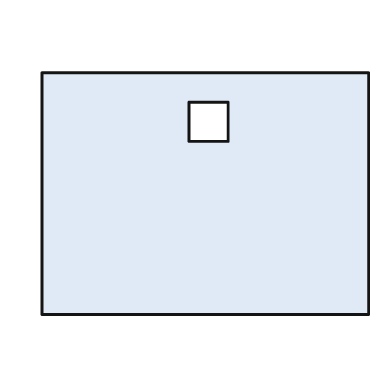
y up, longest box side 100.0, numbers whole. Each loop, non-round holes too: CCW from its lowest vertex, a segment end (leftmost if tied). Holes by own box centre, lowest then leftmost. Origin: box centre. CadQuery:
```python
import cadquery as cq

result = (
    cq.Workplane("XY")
    .moveTo(-50.0, -37.0)
    .lineTo(50.0, -37.0)
    .lineTo(50.0, 37.0)
    .lineTo(-50.0, 37.0)
    .close()
    .moveTo(-5.0, 16.0)
    .lineTo(7.0, 16.0)
    .lineTo(7.0, 28.0)
    .lineTo(-5.0, 28.0)
    .close()
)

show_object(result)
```